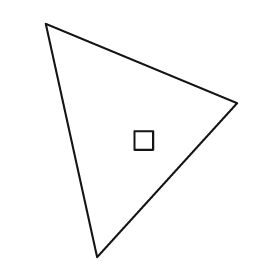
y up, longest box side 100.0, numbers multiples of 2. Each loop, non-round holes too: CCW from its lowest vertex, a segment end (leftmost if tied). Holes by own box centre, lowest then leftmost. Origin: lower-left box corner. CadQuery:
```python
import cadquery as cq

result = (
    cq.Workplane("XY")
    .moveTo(22.0, 0.0)
    .lineTo(82.0, 66.0)
    .lineTo(0.0, 100.0)
    .close()
    .moveTo(38.0, 46.0)
    .lineTo(46.0, 46.0)
    .lineTo(46.0, 54.0)
    .lineTo(38.0, 54.0)
    .close()
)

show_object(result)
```